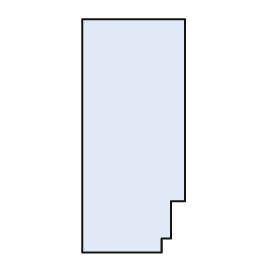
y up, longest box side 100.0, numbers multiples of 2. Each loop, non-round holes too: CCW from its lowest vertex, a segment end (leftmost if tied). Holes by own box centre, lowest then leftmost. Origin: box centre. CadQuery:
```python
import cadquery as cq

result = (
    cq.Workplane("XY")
    .moveTo(-22.0, -50.0)
    .lineTo(12.0, -50.0)
    .lineTo(12.0, -44.0)
    .lineTo(16.0, -44.0)
    .lineTo(16.0, -28.0)
    .lineTo(22.0, -28.0)
    .lineTo(22.0, 50.0)
    .lineTo(-22.0, 50.0)
    .close()
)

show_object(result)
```